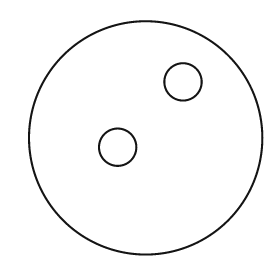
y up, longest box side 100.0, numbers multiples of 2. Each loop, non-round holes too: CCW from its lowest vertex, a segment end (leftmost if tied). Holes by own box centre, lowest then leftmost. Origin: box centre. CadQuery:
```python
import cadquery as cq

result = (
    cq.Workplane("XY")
    .moveTo(0.0, 0.0)
    .circle(50.0)
    .moveTo(-12.0, -4.0)
    .circle(8.0)
    .moveTo(16.0, 24.0)
    .circle(8.0)
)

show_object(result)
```